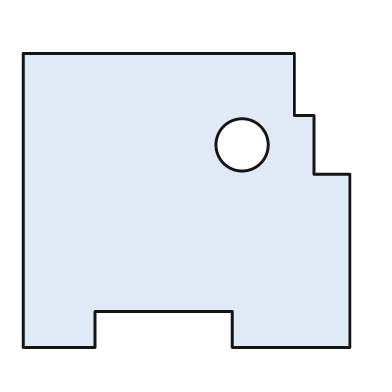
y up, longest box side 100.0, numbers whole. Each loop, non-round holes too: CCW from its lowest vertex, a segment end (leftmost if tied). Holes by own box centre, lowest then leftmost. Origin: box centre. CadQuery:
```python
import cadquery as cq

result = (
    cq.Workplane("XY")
    .moveTo(-50.0, -45.0)
    .lineTo(-28.0, -45.0)
    .lineTo(-28.0, -34.0)
    .lineTo(14.0, -34.0)
    .lineTo(14.0, -45.0)
    .lineTo(50.0, -45.0)
    .lineTo(50.0, 8.0)
    .lineTo(39.0, 8.0)
    .lineTo(39.0, 26.0)
    .lineTo(33.0, 26.0)
    .lineTo(33.0, 45.0)
    .lineTo(-50.0, 45.0)
    .close()
    .moveTo(17.0, 17.0)
    .circle(8.0)
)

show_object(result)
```